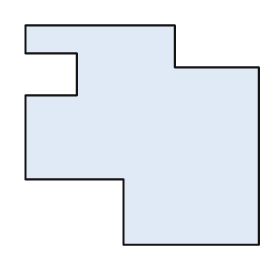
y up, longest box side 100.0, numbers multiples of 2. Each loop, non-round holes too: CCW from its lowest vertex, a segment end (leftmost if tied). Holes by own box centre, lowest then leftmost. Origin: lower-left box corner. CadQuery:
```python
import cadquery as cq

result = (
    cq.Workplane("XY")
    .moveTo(42.0, 0.0)
    .lineTo(100.0, 0.0)
    .lineTo(100.0, 76.0)
    .lineTo(64.0, 76.0)
    .lineTo(64.0, 94.0)
    .lineTo(0.0, 94.0)
    .lineTo(0.0, 82.0)
    .lineTo(22.0, 82.0)
    .lineTo(22.0, 64.0)
    .lineTo(0.0, 64.0)
    .lineTo(0.0, 28.0)
    .lineTo(42.0, 28.0)
    .close()
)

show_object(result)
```